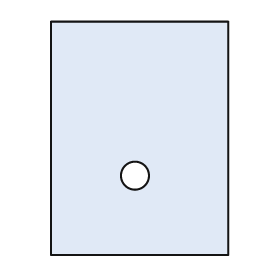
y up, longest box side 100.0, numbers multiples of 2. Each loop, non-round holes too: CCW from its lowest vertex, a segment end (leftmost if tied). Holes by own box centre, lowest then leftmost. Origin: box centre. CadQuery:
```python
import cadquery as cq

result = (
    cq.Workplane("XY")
    .moveTo(-38.0, -50.0)
    .lineTo(38.0, -50.0)
    .lineTo(38.0, 50.0)
    .lineTo(-38.0, 50.0)
    .close()
    .moveTo(-2.0, -16.0)
    .circle(6.0)
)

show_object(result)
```